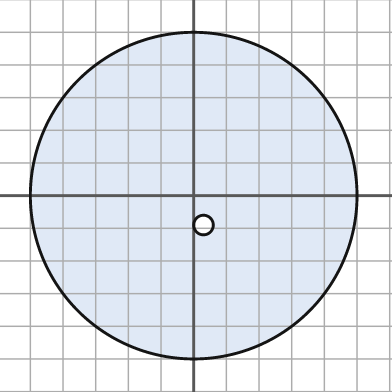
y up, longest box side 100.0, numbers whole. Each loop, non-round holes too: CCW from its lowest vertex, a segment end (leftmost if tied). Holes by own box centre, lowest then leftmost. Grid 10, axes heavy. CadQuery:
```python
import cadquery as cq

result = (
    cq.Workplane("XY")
    .moveTo(0.0, 0.0)
    .circle(50.0)
    .moveTo(3.0, -9.0)
    .circle(3.0)
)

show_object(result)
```